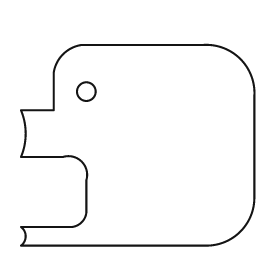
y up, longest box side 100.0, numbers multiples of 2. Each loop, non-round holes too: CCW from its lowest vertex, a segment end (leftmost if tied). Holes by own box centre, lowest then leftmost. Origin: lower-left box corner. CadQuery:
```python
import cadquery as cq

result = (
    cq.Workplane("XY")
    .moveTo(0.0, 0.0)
    .lineTo(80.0, 0.0)
    .threePointArc((94.0, 6.0), (100.0, 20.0))
    .lineTo(100.0, 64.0)
    .threePointArc((94.0, 80.0), (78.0, 86.0))
    .lineTo(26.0, 86.0)
    .threePointArc((18.0, 82.0), (14.0, 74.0))
    .lineTo(14.0, 58.0)
    .lineTo(0.0, 58.0)
    .threePointArc((2.0, 48.0), (0.0, 38.0))
    .lineTo(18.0, 38.0)
    .threePointArc((26.0, 36.0), (28.0, 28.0))
    .lineTo(28.0, 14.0)
    .threePointArc((26.0, 10.0), (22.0, 8.0))
    .lineTo(0.0, 8.0)
    .threePointArc((2.0, 4.0), (0.0, 0.0))
    .close()
    .moveTo(28.0, 66.0)
    .circle(4.0)
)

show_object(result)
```